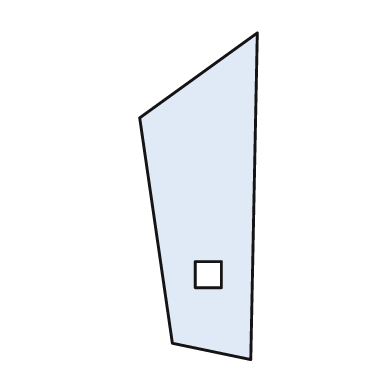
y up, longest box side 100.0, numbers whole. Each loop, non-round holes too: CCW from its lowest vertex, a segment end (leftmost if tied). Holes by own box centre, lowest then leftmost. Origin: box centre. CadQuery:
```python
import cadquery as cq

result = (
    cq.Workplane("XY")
    .moveTo(16.0, -50.0)
    .lineTo(18.0, 50.0)
    .lineTo(-18.0, 24.0)
    .lineTo(-8.0, -45.0)
    .close()
    .moveTo(-1.0, -28.0)
    .lineTo(7.0, -28.0)
    .lineTo(7.0, -20.0)
    .lineTo(-1.0, -20.0)
    .close()
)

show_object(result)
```